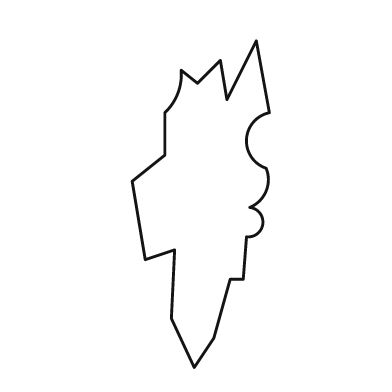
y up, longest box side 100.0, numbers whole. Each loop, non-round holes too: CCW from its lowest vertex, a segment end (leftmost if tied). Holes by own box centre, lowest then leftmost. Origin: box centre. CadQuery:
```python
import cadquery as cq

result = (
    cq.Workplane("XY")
    .moveTo(-2.0, -50.0)
    .lineTo(4.0, -41.0)
    .lineTo(9.0, -23.0)
    .lineTo(13.0, -23.0)
    .lineTo(14.0, -10.0)
    .threePointArc((19.0, -6.0), (15.0, -1.0))
    .threePointArc((20.0, 4.0), (20.0, 11.0))
    .threePointArc((14.0, 20.0), (21.0, 28.0))
    .lineTo(17.0, 50.0)
    .lineTo(8.0, 32.0)
    .lineTo(6.0, 44.0)
    .lineTo(-1.0, 37.0)
    .lineTo(-6.0, 41.0)
    .threePointArc((-7.0, 34.0), (-11.0, 28.0))
    .lineTo(-11.0, 15.0)
    .lineTo(-21.0, 7.0)
    .lineTo(-17.0, -17.0)
    .lineTo(-8.0, -14.0)
    .lineTo(-9.0, -35.0)
    .close()
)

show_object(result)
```